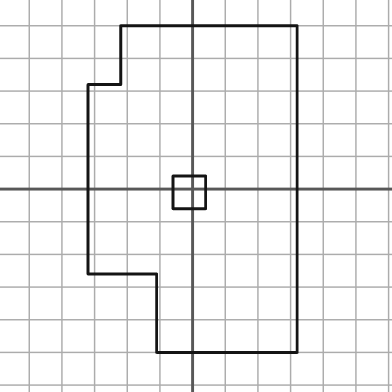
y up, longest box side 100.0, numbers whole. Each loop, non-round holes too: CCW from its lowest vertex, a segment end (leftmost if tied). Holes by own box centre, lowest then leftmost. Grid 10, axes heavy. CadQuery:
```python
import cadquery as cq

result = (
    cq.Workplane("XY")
    .moveTo(-11.0, -50.0)
    .lineTo(32.0, -50.0)
    .lineTo(32.0, 50.0)
    .lineTo(-22.0, 50.0)
    .lineTo(-22.0, 32.0)
    .lineTo(-32.0, 32.0)
    .lineTo(-32.0, -26.0)
    .lineTo(-11.0, -26.0)
    .close()
    .moveTo(-6.0, -6.0)
    .lineTo(4.0, -6.0)
    .lineTo(4.0, 4.0)
    .lineTo(-6.0, 4.0)
    .close()
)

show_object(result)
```